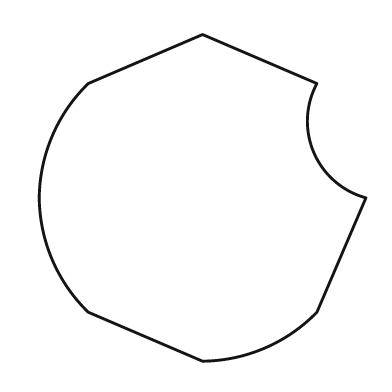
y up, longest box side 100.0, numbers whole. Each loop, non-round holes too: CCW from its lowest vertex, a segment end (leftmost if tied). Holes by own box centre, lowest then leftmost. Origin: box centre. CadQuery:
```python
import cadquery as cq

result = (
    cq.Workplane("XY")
    .moveTo(0.0, -50.0)
    .threePointArc((19.0, -46.0), (35.0, -35.0))
    .lineTo(50.0, 0.0)
    .threePointArc((34.0, 14.0), (35.0, 35.0))
    .lineTo(0.0, 50.0)
    .lineTo(-35.0, 35.0)
    .threePointArc((-46.0, 19.0), (-50.0, 0.0))
    .threePointArc((-46.0, -19.0), (-35.0, -35.0))
    .close()
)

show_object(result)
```